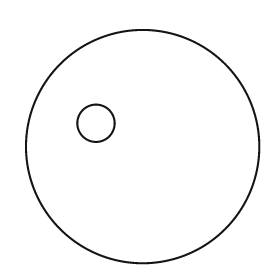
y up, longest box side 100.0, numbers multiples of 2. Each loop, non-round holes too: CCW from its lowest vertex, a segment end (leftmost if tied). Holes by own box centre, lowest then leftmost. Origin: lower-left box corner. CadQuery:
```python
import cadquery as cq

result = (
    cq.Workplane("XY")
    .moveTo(50.0, 50.0)
    .circle(50.0)
    .moveTo(30.0, 60.0)
    .circle(8.0)
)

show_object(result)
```